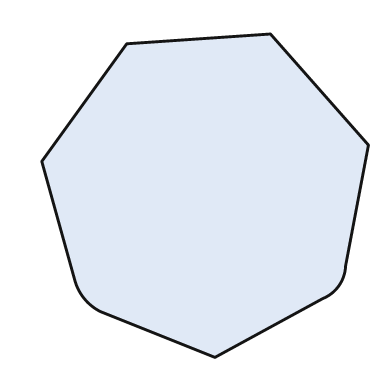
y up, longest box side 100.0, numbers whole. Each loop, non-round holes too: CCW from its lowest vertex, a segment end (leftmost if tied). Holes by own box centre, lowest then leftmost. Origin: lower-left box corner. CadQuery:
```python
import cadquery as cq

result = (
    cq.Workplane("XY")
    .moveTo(53.0, 0.0)
    .lineTo(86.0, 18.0)
    .threePointArc((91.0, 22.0), (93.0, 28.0))
    .lineTo(100.0, 65.0)
    .lineTo(70.0, 99.0)
    .lineTo(26.0, 96.0)
    .lineTo(0.0, 60.0)
    .lineTo(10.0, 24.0)
    .threePointArc((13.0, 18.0), (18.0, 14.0))
    .close()
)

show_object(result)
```